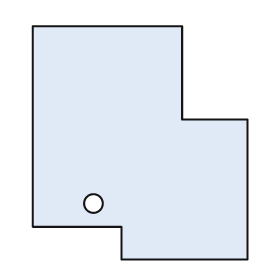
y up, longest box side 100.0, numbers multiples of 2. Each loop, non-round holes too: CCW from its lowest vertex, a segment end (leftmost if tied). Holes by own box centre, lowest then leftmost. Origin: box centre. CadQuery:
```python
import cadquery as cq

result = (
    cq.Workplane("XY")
    .moveTo(-8.0, -50.0)
    .lineTo(46.0, -50.0)
    .lineTo(46.0, 10.0)
    .lineTo(18.0, 10.0)
    .lineTo(18.0, 50.0)
    .lineTo(-46.0, 50.0)
    .lineTo(-46.0, -36.0)
    .lineTo(-8.0, -36.0)
    .close()
    .moveTo(-20.0, -26.0)
    .circle(4.0)
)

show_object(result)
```